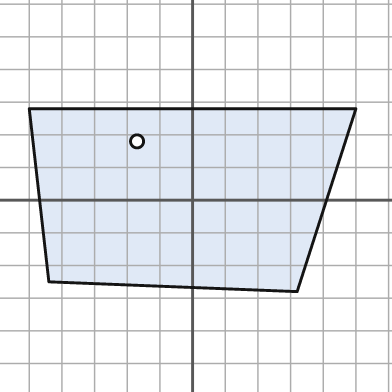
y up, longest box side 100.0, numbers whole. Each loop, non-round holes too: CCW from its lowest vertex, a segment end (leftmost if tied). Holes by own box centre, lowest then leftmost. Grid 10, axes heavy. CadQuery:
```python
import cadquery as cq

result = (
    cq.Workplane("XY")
    .moveTo(32.0, -28.0)
    .lineTo(50.0, 28.0)
    .lineTo(-50.0, 28.0)
    .lineTo(-44.0, -25.0)
    .close()
    .moveTo(-17.0, 18.0)
    .circle(2.0)
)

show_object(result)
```